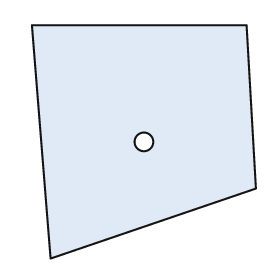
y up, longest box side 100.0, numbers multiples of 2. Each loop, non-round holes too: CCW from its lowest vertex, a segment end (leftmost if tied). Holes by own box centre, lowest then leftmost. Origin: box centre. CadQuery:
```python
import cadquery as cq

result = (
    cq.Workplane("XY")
    .moveTo(-40.0, -50.0)
    .lineTo(48.0, -20.0)
    .lineTo(44.0, 50.0)
    .lineTo(-48.0, 50.0)
    .close()
    .moveTo(0.0, 0.0)
    .circle(4.0)
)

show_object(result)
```